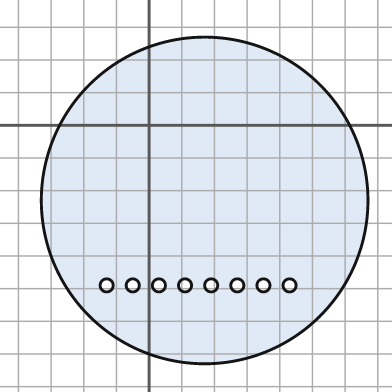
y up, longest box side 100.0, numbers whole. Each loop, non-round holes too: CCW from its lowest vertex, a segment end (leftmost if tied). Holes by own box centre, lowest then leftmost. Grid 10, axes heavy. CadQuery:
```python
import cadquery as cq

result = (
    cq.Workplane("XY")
    .moveTo(17.0, -23.0)
    .circle(50.0)
    .moveTo(-13.0, -49.0)
    .circle(2.0)
    .moveTo(-5.0, -49.0)
    .circle(2.0)
    .moveTo(3.0, -49.0)
    .circle(2.0)
    .moveTo(11.0, -49.0)
    .circle(2.0)
    .moveTo(19.0, -49.0)
    .circle(2.0)
    .moveTo(27.0, -49.0)
    .circle(2.0)
    .moveTo(35.0, -49.0)
    .circle(2.0)
    .moveTo(43.0, -49.0)
    .circle(2.0)
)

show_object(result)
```